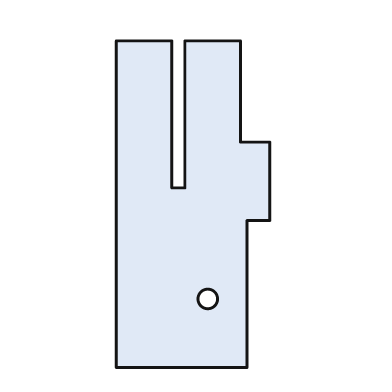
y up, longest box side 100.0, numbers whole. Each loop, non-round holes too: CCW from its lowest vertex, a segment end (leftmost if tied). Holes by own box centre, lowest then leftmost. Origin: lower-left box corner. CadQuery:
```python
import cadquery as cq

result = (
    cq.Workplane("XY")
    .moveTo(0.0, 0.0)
    .lineTo(40.0, 0.0)
    .lineTo(40.0, 45.0)
    .lineTo(47.0, 45.0)
    .lineTo(47.0, 69.0)
    .lineTo(38.0, 69.0)
    .lineTo(38.0, 100.0)
    .lineTo(21.0, 100.0)
    .lineTo(21.0, 55.0)
    .lineTo(17.0, 55.0)
    .lineTo(17.0, 100.0)
    .lineTo(0.0, 100.0)
    .close()
    .moveTo(28.0, 21.0)
    .circle(3.0)
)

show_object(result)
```